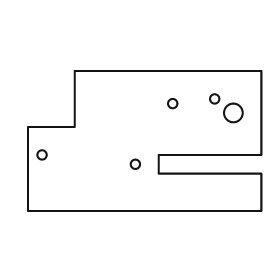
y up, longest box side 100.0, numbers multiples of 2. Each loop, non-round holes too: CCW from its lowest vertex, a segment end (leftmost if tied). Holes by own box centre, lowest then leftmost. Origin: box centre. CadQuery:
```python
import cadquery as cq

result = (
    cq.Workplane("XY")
    .moveTo(-50.0, -30.0)
    .lineTo(50.0, -30.0)
    .lineTo(50.0, -14.0)
    .lineTo(6.0, -14.0)
    .lineTo(6.0, -6.0)
    .lineTo(50.0, -6.0)
    .lineTo(50.0, 30.0)
    .lineTo(-30.0, 30.0)
    .lineTo(-30.0, 6.0)
    .lineTo(-50.0, 6.0)
    .close()
    .moveTo(-4.0, -10.0)
    .circle(2.0)
    .moveTo(-44.0, -6.0)
    .circle(2.0)
    .moveTo(38.0, 12.0)
    .circle(4.0)
    .moveTo(12.0, 16.0)
    .circle(2.0)
    .moveTo(30.0, 18.0)
    .circle(2.0)
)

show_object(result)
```